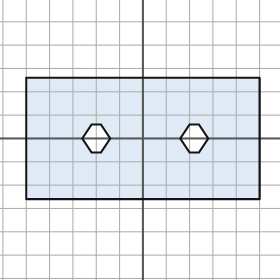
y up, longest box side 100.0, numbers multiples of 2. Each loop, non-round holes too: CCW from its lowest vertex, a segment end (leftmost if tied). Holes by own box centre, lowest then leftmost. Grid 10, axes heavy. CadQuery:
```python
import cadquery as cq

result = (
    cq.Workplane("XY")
    .moveTo(-50.0, -26.0)
    .lineTo(50.0, -26.0)
    .lineTo(50.0, 26.0)
    .lineTo(-50.0, 26.0)
    .close()
    .moveTo(-22.0, -6.0)
    .lineTo(-18.0, -6.0)
    .lineTo(-14.0, 0.0)
    .lineTo(-18.0, 6.0)
    .lineTo(-22.0, 6.0)
    .lineTo(-26.0, 0.0)
    .close()
    .moveTo(20.0, -6.0)
    .lineTo(24.0, -6.0)
    .lineTo(28.0, 0.0)
    .lineTo(24.0, 6.0)
    .lineTo(20.0, 6.0)
    .lineTo(16.0, 0.0)
    .close()
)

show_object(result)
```